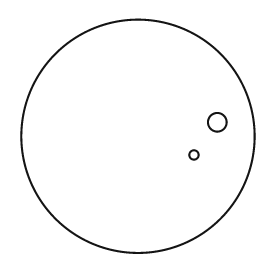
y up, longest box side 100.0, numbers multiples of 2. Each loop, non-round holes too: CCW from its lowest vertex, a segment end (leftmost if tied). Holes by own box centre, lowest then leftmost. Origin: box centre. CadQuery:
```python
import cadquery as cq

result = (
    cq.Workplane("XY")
    .moveTo(0.0, 0.0)
    .circle(50.0)
    .moveTo(24.0, -8.0)
    .circle(2.0)
    .moveTo(34.0, 6.0)
    .circle(4.0)
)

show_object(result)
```